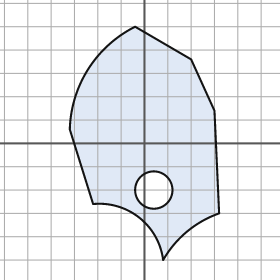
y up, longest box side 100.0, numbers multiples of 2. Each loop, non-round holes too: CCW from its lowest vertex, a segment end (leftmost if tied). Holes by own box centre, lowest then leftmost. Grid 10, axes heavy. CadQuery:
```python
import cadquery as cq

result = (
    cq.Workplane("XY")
    .moveTo(8.0, -50.0)
    .threePointArc((18.0, -38.0), (32.0, -30.0))
    .lineTo(30.0, 14.0)
    .lineTo(20.0, 36.0)
    .lineTo(-4.0, 50.0)
    .threePointArc((-24.0, 32.0), (-32.0, 6.0))
    .lineTo(-22.0, -26.0)
    .threePointArc((-2.0, -32.0), (8.0, -50.0))
    .close()
    .moveTo(4.0, -20.0)
    .circle(8.0)
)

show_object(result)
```